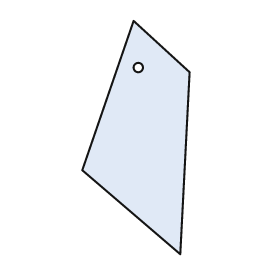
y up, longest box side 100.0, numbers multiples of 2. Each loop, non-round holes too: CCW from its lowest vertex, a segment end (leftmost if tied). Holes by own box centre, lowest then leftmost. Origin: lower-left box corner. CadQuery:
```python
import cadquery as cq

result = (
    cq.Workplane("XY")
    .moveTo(42.0, 0.0)
    .lineTo(46.0, 78.0)
    .lineTo(22.0, 100.0)
    .lineTo(0.0, 36.0)
    .close()
    .moveTo(24.0, 80.0)
    .circle(2.0)
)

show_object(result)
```